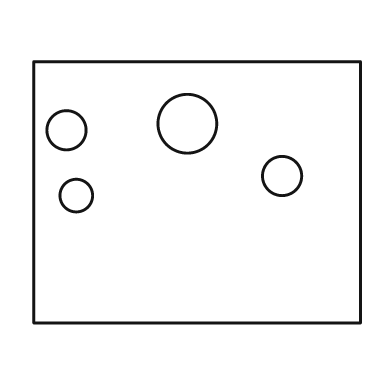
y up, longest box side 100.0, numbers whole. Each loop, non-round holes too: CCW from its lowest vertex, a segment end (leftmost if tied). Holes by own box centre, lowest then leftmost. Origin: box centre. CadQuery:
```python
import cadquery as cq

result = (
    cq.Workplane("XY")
    .moveTo(-50.0, -40.0)
    .lineTo(50.0, -40.0)
    .lineTo(50.0, 40.0)
    .lineTo(-50.0, 40.0)
    .close()
    .moveTo(-37.0, -1.0)
    .circle(5.0)
    .moveTo(26.0, 5.0)
    .circle(6.0)
    .moveTo(-40.0, 19.0)
    .circle(6.0)
    .moveTo(-3.0, 21.0)
    .circle(9.0)
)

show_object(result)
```